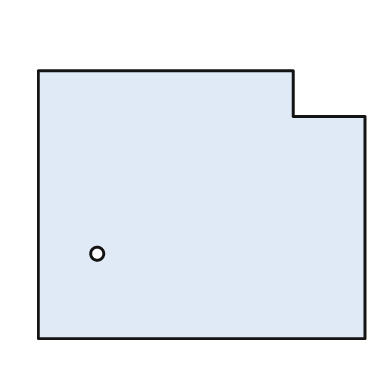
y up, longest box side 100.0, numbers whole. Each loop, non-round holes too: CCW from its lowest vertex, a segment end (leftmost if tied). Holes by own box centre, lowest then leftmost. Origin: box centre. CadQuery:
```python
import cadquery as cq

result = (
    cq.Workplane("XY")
    .moveTo(-50.0, -41.0)
    .lineTo(50.0, -41.0)
    .lineTo(50.0, 27.0)
    .lineTo(28.0, 27.0)
    .lineTo(28.0, 41.0)
    .lineTo(-50.0, 41.0)
    .close()
    .moveTo(-32.0, -15.0)
    .circle(2.0)
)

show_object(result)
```